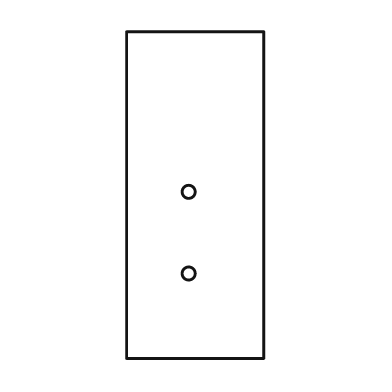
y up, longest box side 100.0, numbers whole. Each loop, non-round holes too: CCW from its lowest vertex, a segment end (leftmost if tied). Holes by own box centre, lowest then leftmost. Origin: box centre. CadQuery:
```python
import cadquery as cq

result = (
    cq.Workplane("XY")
    .moveTo(-21.0, -50.0)
    .lineTo(21.0, -50.0)
    .lineTo(21.0, 50.0)
    .lineTo(-21.0, 50.0)
    .close()
    .moveTo(-2.0, -24.0)
    .circle(2.0)
    .moveTo(-2.0, 1.0)
    .circle(2.0)
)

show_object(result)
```